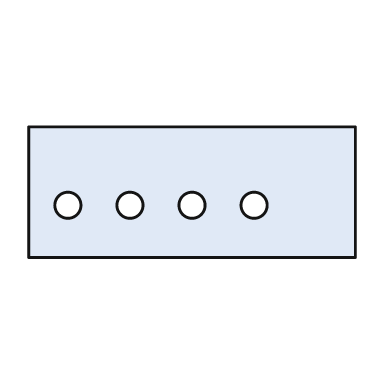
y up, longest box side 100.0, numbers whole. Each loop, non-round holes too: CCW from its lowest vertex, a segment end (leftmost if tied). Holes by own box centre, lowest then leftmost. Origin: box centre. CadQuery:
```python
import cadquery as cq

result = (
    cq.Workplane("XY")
    .moveTo(-50.0, -20.0)
    .lineTo(50.0, -20.0)
    .lineTo(50.0, 20.0)
    .lineTo(-50.0, 20.0)
    .close()
    .moveTo(-38.0, -4.0)
    .circle(4.0)
    .moveTo(-19.0, -4.0)
    .circle(4.0)
    .moveTo(0.0, -4.0)
    .circle(4.0)
    .moveTo(19.0, -4.0)
    .circle(4.0)
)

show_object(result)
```